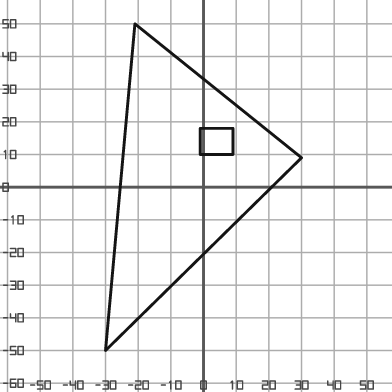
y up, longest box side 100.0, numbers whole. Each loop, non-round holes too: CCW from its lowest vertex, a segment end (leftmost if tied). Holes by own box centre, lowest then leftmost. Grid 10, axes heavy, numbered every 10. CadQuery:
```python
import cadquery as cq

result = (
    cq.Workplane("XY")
    .moveTo(-30.0, -50.0)
    .lineTo(30.0, 9.0)
    .lineTo(-21.0, 50.0)
    .close()
    .moveTo(-1.0, 10.0)
    .lineTo(9.0, 10.0)
    .lineTo(9.0, 18.0)
    .lineTo(-1.0, 18.0)
    .close()
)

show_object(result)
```